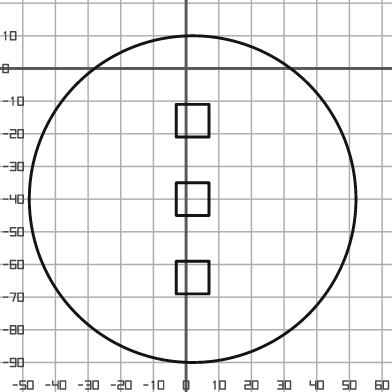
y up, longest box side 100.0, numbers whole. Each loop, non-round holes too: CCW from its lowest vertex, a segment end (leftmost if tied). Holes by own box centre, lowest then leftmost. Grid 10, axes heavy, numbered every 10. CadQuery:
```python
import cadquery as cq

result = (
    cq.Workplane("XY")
    .moveTo(2.0, -40.0)
    .circle(50.0)
    .moveTo(-3.0, -69.0)
    .lineTo(7.0, -69.0)
    .lineTo(7.0, -59.0)
    .lineTo(-3.0, -59.0)
    .close()
    .moveTo(-3.0, -45.0)
    .lineTo(7.0, -45.0)
    .lineTo(7.0, -35.0)
    .lineTo(-3.0, -35.0)
    .close()
    .moveTo(-3.0, -21.0)
    .lineTo(7.0, -21.0)
    .lineTo(7.0, -11.0)
    .lineTo(-3.0, -11.0)
    .close()
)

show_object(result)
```